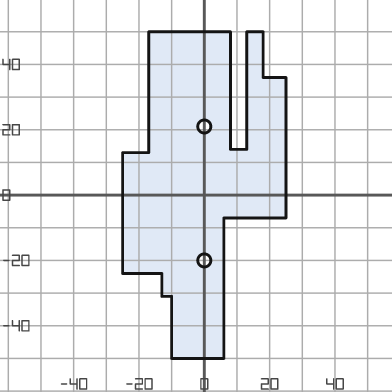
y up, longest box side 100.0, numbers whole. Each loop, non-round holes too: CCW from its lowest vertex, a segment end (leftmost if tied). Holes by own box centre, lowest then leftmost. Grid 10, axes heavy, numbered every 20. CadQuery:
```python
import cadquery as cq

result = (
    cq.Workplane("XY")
    .moveTo(-10.0, -50.0)
    .lineTo(6.0, -50.0)
    .lineTo(6.0, -7.0)
    .lineTo(25.0, -7.0)
    .lineTo(25.0, 36.0)
    .lineTo(18.0, 36.0)
    .lineTo(18.0, 50.0)
    .lineTo(13.0, 50.0)
    .lineTo(13.0, 14.0)
    .lineTo(8.0, 14.0)
    .lineTo(8.0, 50.0)
    .lineTo(-17.0, 50.0)
    .lineTo(-17.0, 13.0)
    .lineTo(-25.0, 13.0)
    .lineTo(-25.0, -24.0)
    .lineTo(-13.0, -24.0)
    .lineTo(-13.0, -31.0)
    .lineTo(-10.0, -31.0)
    .close()
    .moveTo(0.0, -20.0)
    .circle(2.0)
    .moveTo(0.0, 21.0)
    .circle(2.0)
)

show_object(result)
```